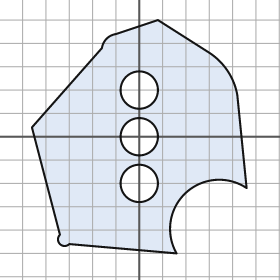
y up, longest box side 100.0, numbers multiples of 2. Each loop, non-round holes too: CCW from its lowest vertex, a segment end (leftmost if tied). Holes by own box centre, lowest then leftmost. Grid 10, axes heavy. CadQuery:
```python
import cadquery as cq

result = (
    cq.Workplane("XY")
    .moveTo(16.0, -50.0)
    .threePointArc((20.0, -24.0), (46.0, -22.0))
    .lineTo(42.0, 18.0)
    .threePointArc((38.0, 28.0), (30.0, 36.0))
    .lineTo(8.0, 50.0)
    .lineTo(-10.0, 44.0)
    .threePointArc((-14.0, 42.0), (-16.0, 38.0))
    .lineTo(-46.0, 4.0)
    .lineTo(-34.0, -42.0)
    .threePointArc((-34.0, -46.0), (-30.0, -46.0))
    .close()
    .moveTo(0.0, -20.0)
    .circle(8.0)
    .moveTo(0.0, 0.0)
    .circle(8.0)
    .moveTo(0.0, 20.0)
    .circle(8.0)
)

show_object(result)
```